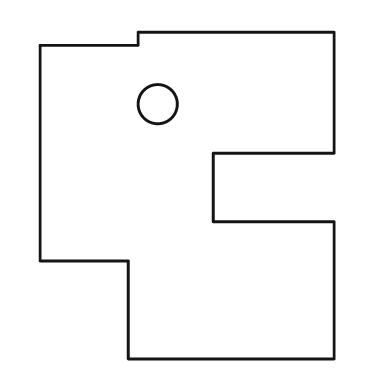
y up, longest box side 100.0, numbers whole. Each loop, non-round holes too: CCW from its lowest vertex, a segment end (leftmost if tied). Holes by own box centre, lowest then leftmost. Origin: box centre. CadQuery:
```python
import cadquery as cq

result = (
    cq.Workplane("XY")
    .moveTo(-18.0, -50.0)
    .lineTo(45.0, -50.0)
    .lineTo(45.0, -8.0)
    .lineTo(8.0, -8.0)
    .lineTo(8.0, 13.0)
    .lineTo(45.0, 13.0)
    .lineTo(45.0, 50.0)
    .lineTo(-15.0, 50.0)
    .lineTo(-15.0, 46.0)
    .lineTo(-45.0, 46.0)
    .lineTo(-45.0, -20.0)
    .lineTo(-18.0, -20.0)
    .close()
    .moveTo(-9.0, 28.0)
    .circle(6.0)
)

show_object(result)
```